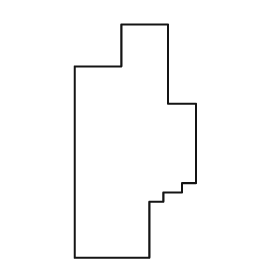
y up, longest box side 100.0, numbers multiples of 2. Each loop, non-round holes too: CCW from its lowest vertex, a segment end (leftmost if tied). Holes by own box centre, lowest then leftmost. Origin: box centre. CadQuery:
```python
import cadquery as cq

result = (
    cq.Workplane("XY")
    .moveTo(-26.0, -50.0)
    .lineTo(6.0, -50.0)
    .lineTo(6.0, -26.0)
    .lineTo(12.0, -26.0)
    .lineTo(12.0, -22.0)
    .lineTo(20.0, -22.0)
    .lineTo(20.0, -18.0)
    .lineTo(26.0, -18.0)
    .lineTo(26.0, 16.0)
    .lineTo(14.0, 16.0)
    .lineTo(14.0, 50.0)
    .lineTo(-6.0, 50.0)
    .lineTo(-6.0, 32.0)
    .lineTo(-26.0, 32.0)
    .close()
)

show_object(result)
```